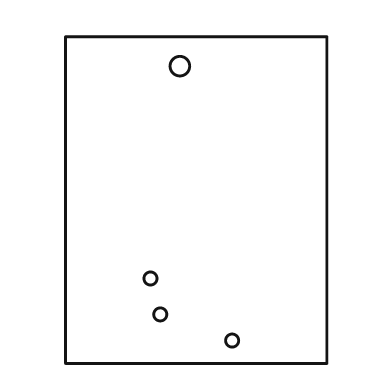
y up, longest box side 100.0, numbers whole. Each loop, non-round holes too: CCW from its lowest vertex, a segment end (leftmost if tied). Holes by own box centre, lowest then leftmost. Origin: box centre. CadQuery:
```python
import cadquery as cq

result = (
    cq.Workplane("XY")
    .moveTo(-40.0, -50.0)
    .lineTo(40.0, -50.0)
    .lineTo(40.0, 50.0)
    .lineTo(-40.0, 50.0)
    .close()
    .moveTo(11.0, -43.0)
    .circle(2.0)
    .moveTo(-11.0, -35.0)
    .circle(2.0)
    .moveTo(-14.0, -24.0)
    .circle(2.0)
    .moveTo(-5.0, 41.0)
    .circle(3.0)
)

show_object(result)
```